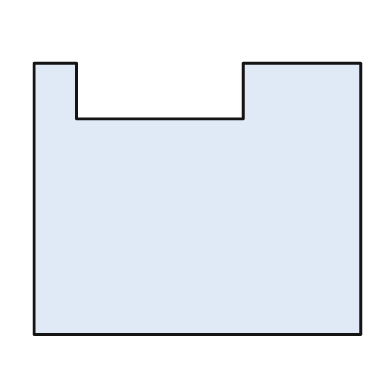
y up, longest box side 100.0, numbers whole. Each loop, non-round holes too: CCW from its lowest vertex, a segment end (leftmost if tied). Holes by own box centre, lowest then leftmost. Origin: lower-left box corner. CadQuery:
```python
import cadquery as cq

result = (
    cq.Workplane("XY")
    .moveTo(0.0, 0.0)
    .lineTo(100.0, 0.0)
    .lineTo(100.0, 83.0)
    .lineTo(64.0, 83.0)
    .lineTo(64.0, 66.0)
    .lineTo(13.0, 66.0)
    .lineTo(13.0, 83.0)
    .lineTo(0.0, 83.0)
    .close()
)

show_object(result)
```